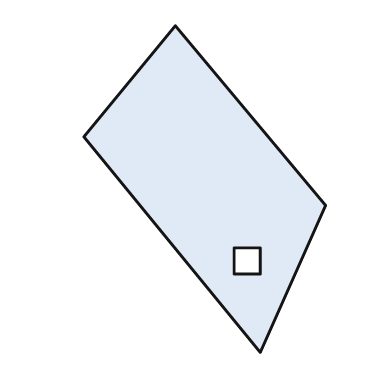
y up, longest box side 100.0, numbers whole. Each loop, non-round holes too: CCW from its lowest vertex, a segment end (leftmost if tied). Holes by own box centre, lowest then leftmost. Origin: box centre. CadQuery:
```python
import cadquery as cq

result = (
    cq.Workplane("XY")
    .moveTo(17.0, -50.0)
    .lineTo(37.0, -5.0)
    .lineTo(-9.0, 50.0)
    .lineTo(-37.0, 16.0)
    .close()
    .moveTo(9.0, -26.0)
    .lineTo(17.0, -26.0)
    .lineTo(17.0, -18.0)
    .lineTo(9.0, -18.0)
    .close()
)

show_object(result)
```